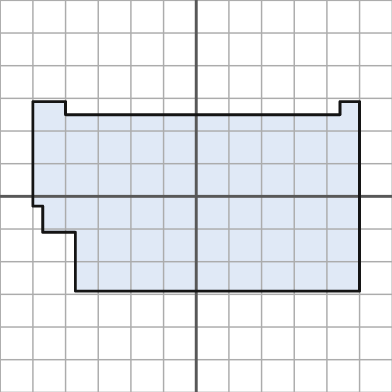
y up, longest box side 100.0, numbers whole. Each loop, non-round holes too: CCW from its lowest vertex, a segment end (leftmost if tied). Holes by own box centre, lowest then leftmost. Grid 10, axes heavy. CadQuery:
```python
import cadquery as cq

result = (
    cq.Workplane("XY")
    .moveTo(-37.0, -29.0)
    .lineTo(50.0, -29.0)
    .lineTo(50.0, 29.0)
    .lineTo(44.0, 29.0)
    .lineTo(44.0, 25.0)
    .lineTo(-40.0, 25.0)
    .lineTo(-40.0, 29.0)
    .lineTo(-50.0, 29.0)
    .lineTo(-50.0, -3.0)
    .lineTo(-47.0, -3.0)
    .lineTo(-47.0, -11.0)
    .lineTo(-37.0, -11.0)
    .close()
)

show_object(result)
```